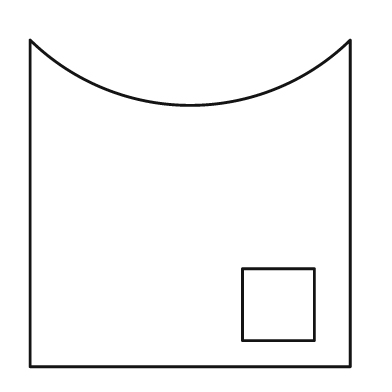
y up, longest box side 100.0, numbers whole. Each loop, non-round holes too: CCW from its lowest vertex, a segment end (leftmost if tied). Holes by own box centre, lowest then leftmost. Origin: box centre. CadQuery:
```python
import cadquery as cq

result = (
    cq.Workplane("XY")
    .moveTo(-49.0, -50.0)
    .lineTo(49.0, -50.0)
    .lineTo(49.0, 50.0)
    .threePointArc((0.0, 30.0), (-49.0, 50.0))
    .close()
    .moveTo(16.0, -42.0)
    .lineTo(38.0, -42.0)
    .lineTo(38.0, -20.0)
    .lineTo(16.0, -20.0)
    .close()
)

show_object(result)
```